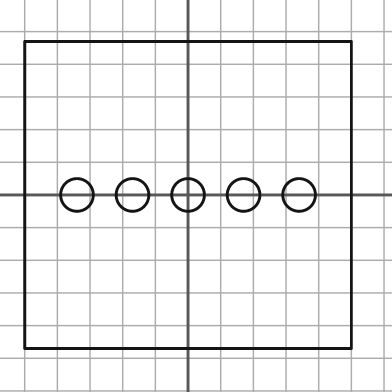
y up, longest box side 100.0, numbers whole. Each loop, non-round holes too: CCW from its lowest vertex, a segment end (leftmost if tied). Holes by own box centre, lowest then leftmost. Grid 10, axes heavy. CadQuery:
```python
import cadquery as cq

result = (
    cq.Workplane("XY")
    .moveTo(-50.0, -47.0)
    .lineTo(50.0, -47.0)
    .lineTo(50.0, 47.0)
    .lineTo(-50.0, 47.0)
    .close()
    .moveTo(-34.0, 0.0)
    .circle(5.0)
    .moveTo(-17.0, 0.0)
    .circle(5.0)
    .moveTo(0.0, 0.0)
    .circle(5.0)
    .moveTo(17.0, 0.0)
    .circle(5.0)
    .moveTo(34.0, 0.0)
    .circle(5.0)
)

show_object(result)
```